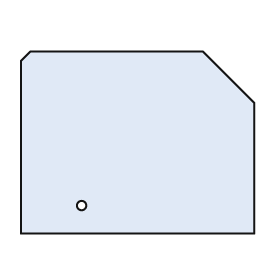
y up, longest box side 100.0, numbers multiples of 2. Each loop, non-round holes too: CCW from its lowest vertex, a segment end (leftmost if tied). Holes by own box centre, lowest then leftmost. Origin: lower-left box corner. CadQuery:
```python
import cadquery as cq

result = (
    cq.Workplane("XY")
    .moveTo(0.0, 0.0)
    .lineTo(100.0, 0.0)
    .lineTo(100.0, 56.0)
    .lineTo(78.0, 78.0)
    .lineTo(4.0, 78.0)
    .lineTo(0.0, 74.0)
    .close()
    .moveTo(26.0, 12.0)
    .circle(2.0)
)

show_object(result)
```